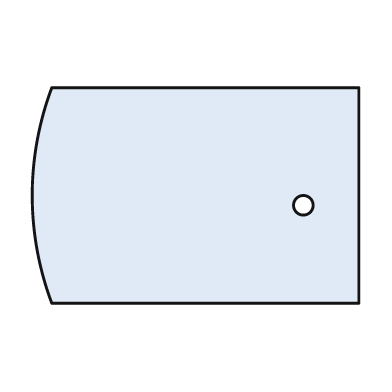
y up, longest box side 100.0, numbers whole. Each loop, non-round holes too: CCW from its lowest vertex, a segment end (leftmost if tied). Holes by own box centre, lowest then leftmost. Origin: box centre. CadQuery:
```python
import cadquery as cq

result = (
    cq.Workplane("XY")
    .moveTo(-44.0, -33.0)
    .lineTo(50.0, -33.0)
    .lineTo(50.0, 33.0)
    .lineTo(-44.0, 33.0)
    .threePointArc((-50.0, 0.0), (-44.0, -33.0))
    .close()
    .moveTo(33.0, -3.0)
    .circle(3.0)
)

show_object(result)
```